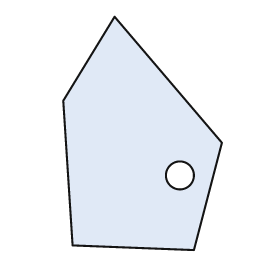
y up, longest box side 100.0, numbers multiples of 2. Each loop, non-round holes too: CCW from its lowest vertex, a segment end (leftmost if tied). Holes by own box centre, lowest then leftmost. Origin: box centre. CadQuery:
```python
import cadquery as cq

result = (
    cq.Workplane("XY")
    .moveTo(22.0, -50.0)
    .lineTo(34.0, -4.0)
    .lineTo(-12.0, 50.0)
    .lineTo(-34.0, 14.0)
    .lineTo(-30.0, -48.0)
    .close()
    .moveTo(16.0, -18.0)
    .circle(6.0)
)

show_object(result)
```